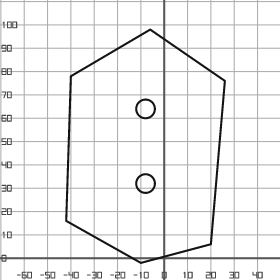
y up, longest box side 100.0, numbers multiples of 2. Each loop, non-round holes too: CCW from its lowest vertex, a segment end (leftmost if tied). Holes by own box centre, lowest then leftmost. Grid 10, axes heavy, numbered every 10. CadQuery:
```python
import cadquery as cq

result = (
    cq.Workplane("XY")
    .moveTo(-10.0, -2.0)
    .lineTo(20.0, 6.0)
    .lineTo(26.0, 76.0)
    .lineTo(-6.0, 98.0)
    .lineTo(-40.0, 78.0)
    .lineTo(-42.0, 16.0)
    .close()
    .moveTo(-8.0, 32.0)
    .circle(4.0)
    .moveTo(-8.0, 64.0)
    .circle(4.0)
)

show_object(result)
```